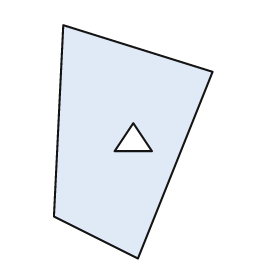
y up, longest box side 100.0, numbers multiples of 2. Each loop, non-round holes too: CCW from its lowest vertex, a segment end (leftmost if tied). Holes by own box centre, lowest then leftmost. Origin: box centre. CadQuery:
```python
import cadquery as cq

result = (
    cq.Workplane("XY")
    .moveTo(2.0, -50.0)
    .lineTo(34.0, 30.0)
    .lineTo(-30.0, 50.0)
    .lineTo(-34.0, -32.0)
    .close()
    .moveTo(-8.0, -4.0)
    .lineTo(8.0, -4.0)
    .lineTo(0.0, 8.0)
    .close()
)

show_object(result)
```